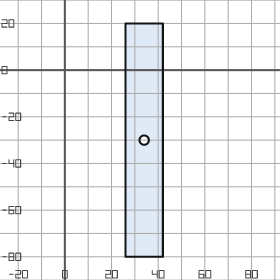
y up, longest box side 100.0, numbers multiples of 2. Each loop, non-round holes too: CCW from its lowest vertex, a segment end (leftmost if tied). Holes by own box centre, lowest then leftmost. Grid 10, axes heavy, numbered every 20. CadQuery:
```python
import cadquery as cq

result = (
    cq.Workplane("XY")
    .moveTo(26.0, -80.0)
    .lineTo(42.0, -80.0)
    .lineTo(42.0, 20.0)
    .lineTo(26.0, 20.0)
    .close()
    .moveTo(34.0, -30.0)
    .circle(2.0)
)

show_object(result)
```